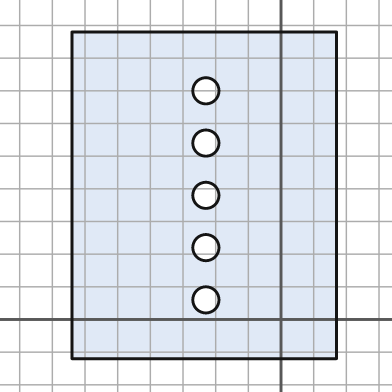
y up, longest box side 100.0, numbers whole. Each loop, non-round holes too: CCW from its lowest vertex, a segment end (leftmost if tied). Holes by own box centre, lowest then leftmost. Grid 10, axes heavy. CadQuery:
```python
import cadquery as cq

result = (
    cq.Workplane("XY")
    .moveTo(-64.0, -12.0)
    .lineTo(17.0, -12.0)
    .lineTo(17.0, 88.0)
    .lineTo(-64.0, 88.0)
    .close()
    .moveTo(-23.0, 6.0)
    .circle(4.0)
    .moveTo(-23.0, 22.0)
    .circle(4.0)
    .moveTo(-23.0, 38.0)
    .circle(4.0)
    .moveTo(-23.0, 54.0)
    .circle(4.0)
    .moveTo(-23.0, 70.0)
    .circle(4.0)
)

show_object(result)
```